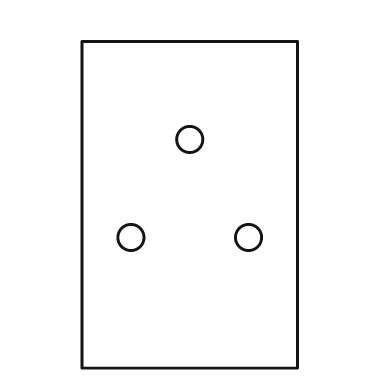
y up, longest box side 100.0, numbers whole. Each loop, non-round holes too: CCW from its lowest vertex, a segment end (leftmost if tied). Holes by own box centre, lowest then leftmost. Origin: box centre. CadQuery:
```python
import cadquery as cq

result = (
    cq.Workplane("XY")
    .moveTo(-33.0, -50.0)
    .lineTo(33.0, -50.0)
    .lineTo(33.0, 50.0)
    .lineTo(-33.0, 50.0)
    .close()
    .moveTo(-18.0, -10.0)
    .circle(4.0)
    .moveTo(18.0, -10.0)
    .circle(4.0)
    .moveTo(0.0, 20.0)
    .circle(4.0)
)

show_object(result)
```